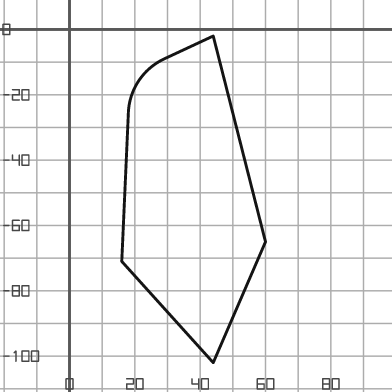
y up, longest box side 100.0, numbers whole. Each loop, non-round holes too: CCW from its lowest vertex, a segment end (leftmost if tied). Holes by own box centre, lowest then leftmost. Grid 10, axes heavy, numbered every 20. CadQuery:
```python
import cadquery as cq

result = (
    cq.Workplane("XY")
    .moveTo(44.0, -102.0)
    .lineTo(60.0, -65.0)
    .lineTo(44.0, -2.0)
    .lineTo(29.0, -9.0)
    .threePointArc((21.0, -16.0), (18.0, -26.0))
    .lineTo(16.0, -71.0)
    .close()
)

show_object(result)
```